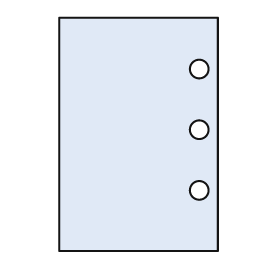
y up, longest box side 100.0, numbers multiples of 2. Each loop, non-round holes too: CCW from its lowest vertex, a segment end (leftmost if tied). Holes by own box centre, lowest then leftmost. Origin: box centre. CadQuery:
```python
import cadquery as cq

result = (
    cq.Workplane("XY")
    .moveTo(-34.0, -50.0)
    .lineTo(34.0, -50.0)
    .lineTo(34.0, 50.0)
    .lineTo(-34.0, 50.0)
    .close()
    .moveTo(26.0, -24.0)
    .circle(4.0)
    .moveTo(26.0, 2.0)
    .circle(4.0)
    .moveTo(26.0, 28.0)
    .circle(4.0)
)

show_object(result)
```